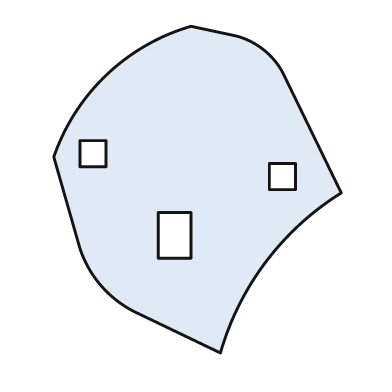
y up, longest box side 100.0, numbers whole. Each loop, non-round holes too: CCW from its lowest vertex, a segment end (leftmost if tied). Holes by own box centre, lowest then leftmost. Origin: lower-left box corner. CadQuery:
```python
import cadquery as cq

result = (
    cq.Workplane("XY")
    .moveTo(51.0, 0.0)
    .threePointArc((65.0, 28.0), (88.0, 49.0))
    .lineTo(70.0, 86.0)
    .threePointArc((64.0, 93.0), (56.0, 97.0))
    .lineTo(42.0, 100.0)
    .threePointArc((16.0, 85.0), (0.0, 60.0))
    .lineTo(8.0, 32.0)
    .threePointArc((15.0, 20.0), (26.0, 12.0))
    .close()
    .moveTo(32.0, 29.0)
    .lineTo(42.0, 29.0)
    .lineTo(42.0, 43.0)
    .lineTo(32.0, 43.0)
    .close()
    .moveTo(66.0, 50.0)
    .lineTo(74.0, 50.0)
    .lineTo(74.0, 58.0)
    .lineTo(66.0, 58.0)
    .close()
    .moveTo(8.0, 57.0)
    .lineTo(16.0, 57.0)
    .lineTo(16.0, 65.0)
    .lineTo(8.0, 65.0)
    .close()
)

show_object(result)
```